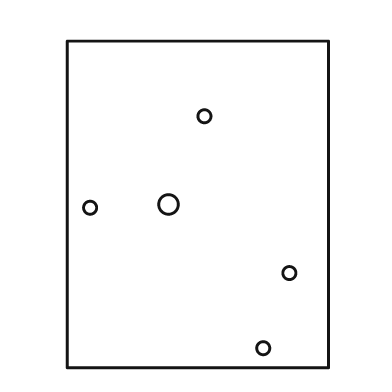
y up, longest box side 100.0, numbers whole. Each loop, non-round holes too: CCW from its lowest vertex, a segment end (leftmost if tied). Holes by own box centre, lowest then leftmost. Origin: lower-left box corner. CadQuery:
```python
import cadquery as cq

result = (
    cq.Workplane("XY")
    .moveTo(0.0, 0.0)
    .lineTo(80.0, 0.0)
    .lineTo(80.0, 100.0)
    .lineTo(0.0, 100.0)
    .close()
    .moveTo(60.0, 6.0)
    .circle(2.0)
    .moveTo(68.0, 29.0)
    .circle(2.0)
    .moveTo(7.0, 49.0)
    .circle(2.0)
    .moveTo(31.0, 50.0)
    .circle(3.0)
    .moveTo(42.0, 77.0)
    .circle(2.0)
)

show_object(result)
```